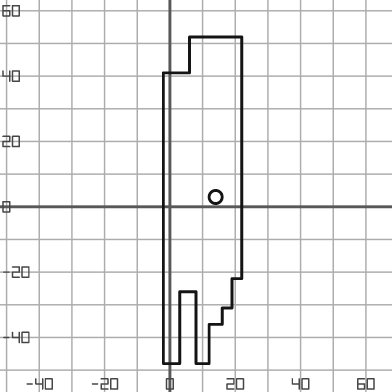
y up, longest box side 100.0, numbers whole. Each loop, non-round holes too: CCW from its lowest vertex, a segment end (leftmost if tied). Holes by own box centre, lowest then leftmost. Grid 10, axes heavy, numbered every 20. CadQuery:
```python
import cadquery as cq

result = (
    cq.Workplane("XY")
    .moveTo(-2.0, -48.0)
    .lineTo(3.0, -48.0)
    .lineTo(3.0, -26.0)
    .lineTo(8.0, -26.0)
    .lineTo(8.0, -48.0)
    .lineTo(12.0, -48.0)
    .lineTo(12.0, -36.0)
    .lineTo(16.0, -36.0)
    .lineTo(16.0, -31.0)
    .lineTo(19.0, -31.0)
    .lineTo(19.0, -22.0)
    .lineTo(22.0, -22.0)
    .lineTo(22.0, 52.0)
    .lineTo(6.0, 52.0)
    .lineTo(6.0, 41.0)
    .lineTo(-2.0, 41.0)
    .close()
    .moveTo(14.0, 3.0)
    .circle(2.0)
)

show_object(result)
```